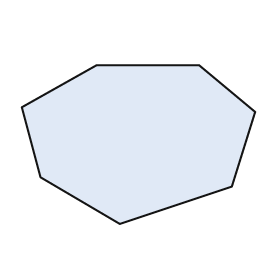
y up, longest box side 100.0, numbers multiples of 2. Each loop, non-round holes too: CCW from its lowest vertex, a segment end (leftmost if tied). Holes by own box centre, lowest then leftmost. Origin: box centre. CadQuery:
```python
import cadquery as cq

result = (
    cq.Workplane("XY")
    .moveTo(-8.0, -34.0)
    .lineTo(40.0, -18.0)
    .lineTo(50.0, 14.0)
    .lineTo(26.0, 34.0)
    .lineTo(-18.0, 34.0)
    .lineTo(-50.0, 16.0)
    .lineTo(-42.0, -14.0)
    .close()
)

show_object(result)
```